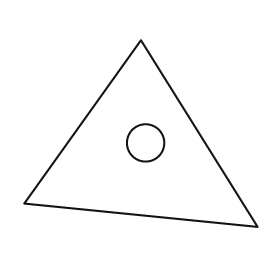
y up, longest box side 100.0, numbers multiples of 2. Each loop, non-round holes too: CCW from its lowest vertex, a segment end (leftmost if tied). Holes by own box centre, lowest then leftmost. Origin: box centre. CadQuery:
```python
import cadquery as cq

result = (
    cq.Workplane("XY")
    .moveTo(50.0, -40.0)
    .lineTo(0.0, 40.0)
    .lineTo(-50.0, -30.0)
    .close()
    .moveTo(2.0, -4.0)
    .circle(8.0)
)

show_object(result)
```